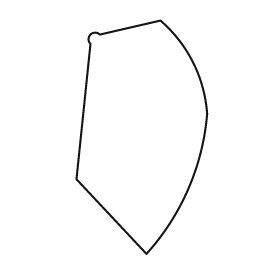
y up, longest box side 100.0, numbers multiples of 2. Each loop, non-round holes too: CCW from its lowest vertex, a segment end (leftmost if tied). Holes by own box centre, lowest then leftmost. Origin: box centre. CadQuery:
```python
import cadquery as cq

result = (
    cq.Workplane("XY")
    .moveTo(2.0, -50.0)
    .threePointArc((20.0, -22.0), (28.0, 10.0))
    .threePointArc((22.0, 32.0), (8.0, 50.0))
    .lineTo(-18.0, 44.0)
    .threePointArc((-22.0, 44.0), (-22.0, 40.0))
    .lineTo(-28.0, -18.0)
    .close()
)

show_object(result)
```